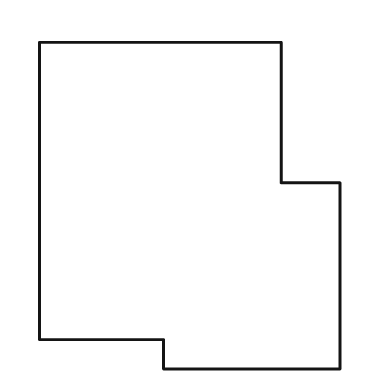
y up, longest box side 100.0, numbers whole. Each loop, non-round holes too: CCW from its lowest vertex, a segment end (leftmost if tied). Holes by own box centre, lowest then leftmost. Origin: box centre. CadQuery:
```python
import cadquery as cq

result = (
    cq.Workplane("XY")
    .moveTo(-8.0, -50.0)
    .lineTo(46.0, -50.0)
    .lineTo(46.0, 7.0)
    .lineTo(28.0, 7.0)
    .lineTo(28.0, 50.0)
    .lineTo(-46.0, 50.0)
    .lineTo(-46.0, -41.0)
    .lineTo(-8.0, -41.0)
    .close()
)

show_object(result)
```